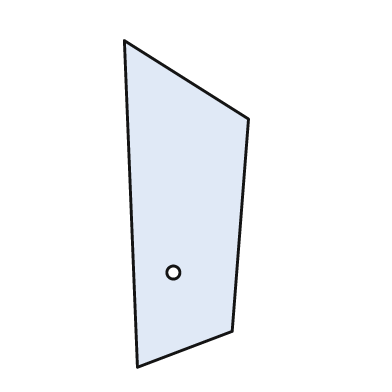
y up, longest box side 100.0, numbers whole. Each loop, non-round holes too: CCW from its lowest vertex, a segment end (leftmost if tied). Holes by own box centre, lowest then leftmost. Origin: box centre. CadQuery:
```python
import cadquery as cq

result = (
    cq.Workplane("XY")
    .moveTo(-15.0, -50.0)
    .lineTo(14.0, -39.0)
    .lineTo(19.0, 26.0)
    .lineTo(-19.0, 50.0)
    .close()
    .moveTo(-4.0, -21.0)
    .circle(2.0)
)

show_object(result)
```